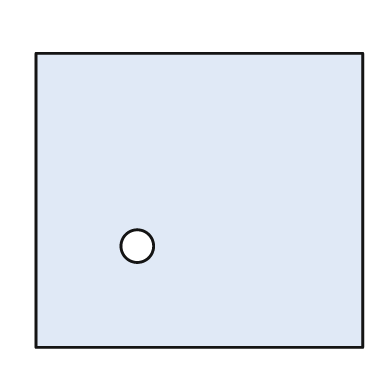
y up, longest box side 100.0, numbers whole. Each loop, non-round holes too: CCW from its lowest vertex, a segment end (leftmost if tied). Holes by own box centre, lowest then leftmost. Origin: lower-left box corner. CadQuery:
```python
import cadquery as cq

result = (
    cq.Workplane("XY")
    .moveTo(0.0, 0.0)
    .lineTo(100.0, 0.0)
    .lineTo(100.0, 90.0)
    .lineTo(0.0, 90.0)
    .close()
    .moveTo(31.0, 31.0)
    .circle(5.0)
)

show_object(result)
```